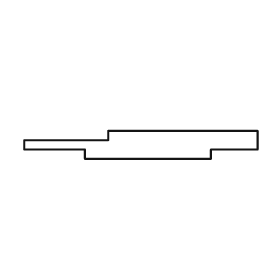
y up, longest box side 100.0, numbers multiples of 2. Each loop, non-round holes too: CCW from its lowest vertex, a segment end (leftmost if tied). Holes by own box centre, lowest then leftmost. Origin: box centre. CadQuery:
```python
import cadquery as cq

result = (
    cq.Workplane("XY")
    .moveTo(-24.0, -6.0)
    .lineTo(30.0, -6.0)
    .lineTo(30.0, -2.0)
    .lineTo(50.0, -2.0)
    .lineTo(50.0, 6.0)
    .lineTo(-14.0, 6.0)
    .lineTo(-14.0, 2.0)
    .lineTo(-50.0, 2.0)
    .lineTo(-50.0, -2.0)
    .lineTo(-24.0, -2.0)
    .close()
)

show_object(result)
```